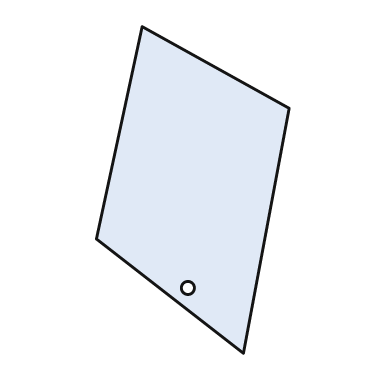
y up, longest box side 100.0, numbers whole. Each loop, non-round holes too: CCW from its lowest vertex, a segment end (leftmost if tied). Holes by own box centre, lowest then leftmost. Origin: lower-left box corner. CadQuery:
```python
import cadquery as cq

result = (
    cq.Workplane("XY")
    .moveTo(45.0, 0.0)
    .lineTo(59.0, 75.0)
    .lineTo(14.0, 100.0)
    .lineTo(0.0, 35.0)
    .close()
    .moveTo(28.0, 20.0)
    .circle(2.0)
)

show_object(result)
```